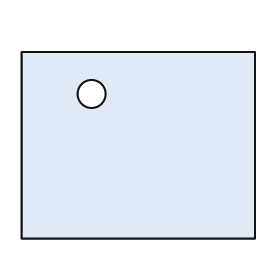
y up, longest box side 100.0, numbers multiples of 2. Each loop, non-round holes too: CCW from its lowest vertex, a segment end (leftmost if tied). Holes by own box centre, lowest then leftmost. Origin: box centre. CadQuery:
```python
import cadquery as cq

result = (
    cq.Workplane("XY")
    .moveTo(-50.0, -40.0)
    .lineTo(50.0, -40.0)
    .lineTo(50.0, 40.0)
    .lineTo(-50.0, 40.0)
    .close()
    .moveTo(-20.0, 22.0)
    .circle(6.0)
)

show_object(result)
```